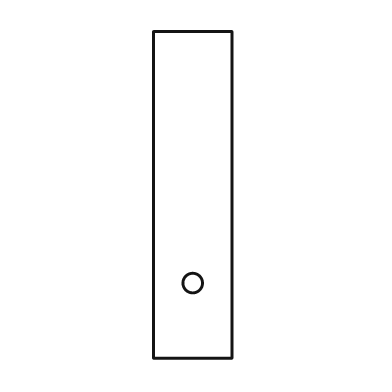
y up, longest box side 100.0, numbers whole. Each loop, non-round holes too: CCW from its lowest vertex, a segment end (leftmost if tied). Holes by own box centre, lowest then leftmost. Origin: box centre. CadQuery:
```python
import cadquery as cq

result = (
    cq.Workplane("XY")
    .moveTo(-12.0, -50.0)
    .lineTo(12.0, -50.0)
    .lineTo(12.0, 50.0)
    .lineTo(-12.0, 50.0)
    .close()
    .moveTo(0.0, -27.0)
    .circle(3.0)
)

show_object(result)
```